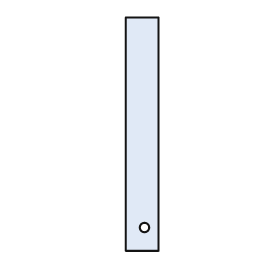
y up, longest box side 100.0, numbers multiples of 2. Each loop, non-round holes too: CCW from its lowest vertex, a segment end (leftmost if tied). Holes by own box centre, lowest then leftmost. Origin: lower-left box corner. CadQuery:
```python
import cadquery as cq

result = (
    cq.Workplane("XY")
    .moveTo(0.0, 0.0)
    .lineTo(14.0, 0.0)
    .lineTo(14.0, 100.0)
    .lineTo(0.0, 100.0)
    .close()
    .moveTo(8.0, 10.0)
    .circle(2.0)
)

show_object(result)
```